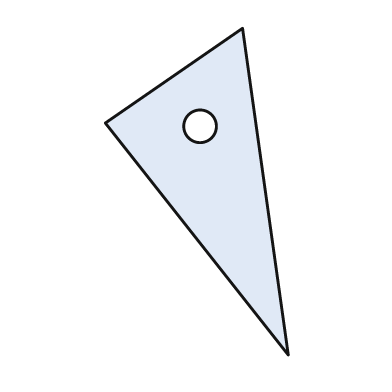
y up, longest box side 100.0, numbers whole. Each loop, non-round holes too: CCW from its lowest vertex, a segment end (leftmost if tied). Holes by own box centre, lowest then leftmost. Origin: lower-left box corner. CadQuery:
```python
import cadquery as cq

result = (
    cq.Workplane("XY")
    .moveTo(56.0, 0.0)
    .lineTo(42.0, 100.0)
    .lineTo(0.0, 71.0)
    .close()
    .moveTo(29.0, 70.0)
    .circle(5.0)
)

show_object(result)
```